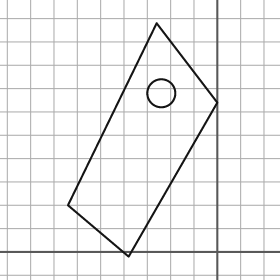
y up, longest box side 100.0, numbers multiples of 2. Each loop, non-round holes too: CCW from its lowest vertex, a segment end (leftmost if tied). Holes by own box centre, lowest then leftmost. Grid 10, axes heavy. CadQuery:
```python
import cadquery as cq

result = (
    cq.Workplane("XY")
    .moveTo(-38.0, -2.0)
    .lineTo(0.0, 64.0)
    .lineTo(-26.0, 98.0)
    .lineTo(-64.0, 20.0)
    .close()
    .moveTo(-24.0, 68.0)
    .circle(6.0)
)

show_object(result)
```